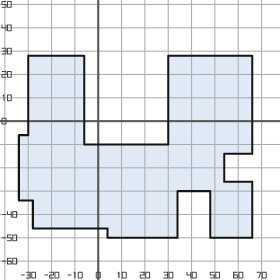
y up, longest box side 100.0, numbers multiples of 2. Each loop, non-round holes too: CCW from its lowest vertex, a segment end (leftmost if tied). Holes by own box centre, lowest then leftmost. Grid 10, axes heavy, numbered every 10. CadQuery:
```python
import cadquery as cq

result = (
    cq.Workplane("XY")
    .moveTo(4.0, -50.0)
    .lineTo(34.0, -50.0)
    .lineTo(34.0, -30.0)
    .lineTo(48.0, -30.0)
    .lineTo(48.0, -50.0)
    .lineTo(66.0, -50.0)
    .lineTo(66.0, -26.0)
    .lineTo(54.0, -26.0)
    .lineTo(54.0, -14.0)
    .lineTo(66.0, -14.0)
    .lineTo(66.0, 28.0)
    .lineTo(30.0, 28.0)
    .lineTo(30.0, -10.0)
    .lineTo(-6.0, -10.0)
    .lineTo(-6.0, 28.0)
    .lineTo(-30.0, 28.0)
    .lineTo(-30.0, -6.0)
    .lineTo(-34.0, -6.0)
    .lineTo(-34.0, -34.0)
    .lineTo(-28.0, -34.0)
    .lineTo(-28.0, -46.0)
    .lineTo(4.0, -46.0)
    .close()
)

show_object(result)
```